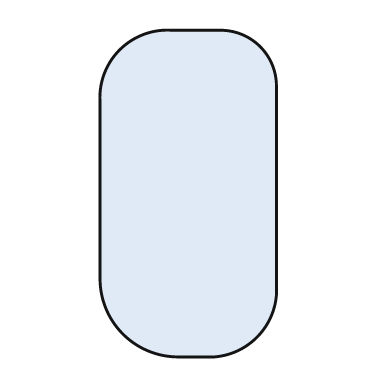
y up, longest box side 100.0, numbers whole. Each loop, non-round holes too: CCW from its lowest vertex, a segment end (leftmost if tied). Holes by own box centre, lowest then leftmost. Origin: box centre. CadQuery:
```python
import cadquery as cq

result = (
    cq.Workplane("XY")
    .moveTo(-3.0, -50.0)
    .lineTo(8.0, -50.0)
    .threePointArc((21.0, -44.0), (27.0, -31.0))
    .lineTo(27.0, 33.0)
    .threePointArc((22.0, 45.0), (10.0, 50.0))
    .lineTo(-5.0, 50.0)
    .threePointArc((-21.0, 44.0), (-27.0, 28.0))
    .lineTo(-27.0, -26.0)
    .threePointArc((-20.0, -43.0), (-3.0, -50.0))
    .close()
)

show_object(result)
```